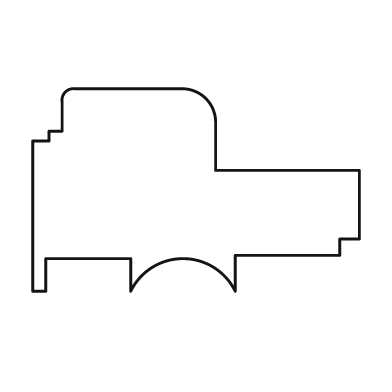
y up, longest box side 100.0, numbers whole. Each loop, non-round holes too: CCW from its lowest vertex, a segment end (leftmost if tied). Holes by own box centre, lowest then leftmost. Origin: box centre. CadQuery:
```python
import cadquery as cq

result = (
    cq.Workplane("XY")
    .moveTo(-50.0, -31.0)
    .lineTo(-46.0, -31.0)
    .lineTo(-46.0, -21.0)
    .lineTo(-20.0, -21.0)
    .lineTo(-20.0, -31.0)
    .threePointArc((-4.0, -21.0), (12.0, -31.0))
    .lineTo(12.0, -20.0)
    .lineTo(44.0, -20.0)
    .lineTo(44.0, -15.0)
    .lineTo(50.0, -15.0)
    .lineTo(50.0, 6.0)
    .lineTo(6.0, 6.0)
    .lineTo(6.0, 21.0)
    .threePointArc((3.0, 28.0), (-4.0, 31.0))
    .lineTo(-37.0, 31.0)
    .threePointArc((-40.0, 30.0), (-41.0, 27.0))
    .lineTo(-41.0, 18.0)
    .lineTo(-45.0, 18.0)
    .lineTo(-45.0, 15.0)
    .lineTo(-50.0, 15.0)
    .close()
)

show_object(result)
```